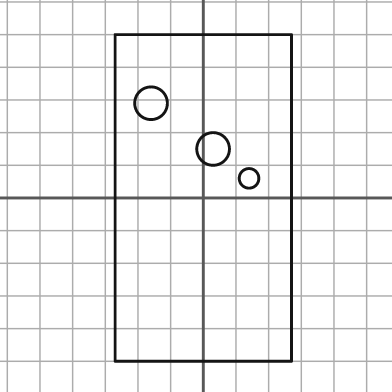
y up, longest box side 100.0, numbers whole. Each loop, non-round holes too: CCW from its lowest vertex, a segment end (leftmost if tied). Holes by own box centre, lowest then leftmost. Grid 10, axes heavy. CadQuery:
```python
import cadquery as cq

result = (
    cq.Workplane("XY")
    .moveTo(-27.0, -50.0)
    .lineTo(27.0, -50.0)
    .lineTo(27.0, 50.0)
    .lineTo(-27.0, 50.0)
    .close()
    .moveTo(14.0, 6.0)
    .circle(3.0)
    .moveTo(3.0, 15.0)
    .circle(5.0)
    .moveTo(-16.0, 29.0)
    .circle(5.0)
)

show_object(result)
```